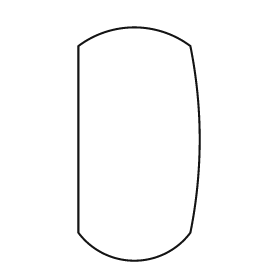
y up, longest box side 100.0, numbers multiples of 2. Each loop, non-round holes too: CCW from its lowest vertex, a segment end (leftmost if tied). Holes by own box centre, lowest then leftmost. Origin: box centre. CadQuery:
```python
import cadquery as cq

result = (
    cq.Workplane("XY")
    .moveTo(-26.0, -38.0)
    .threePointArc((-2.0, -50.0), (22.0, -38.0))
    .threePointArc((26.0, 2.0), (22.0, 42.0))
    .threePointArc((-2.0, 50.0), (-26.0, 42.0))
    .close()
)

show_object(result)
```